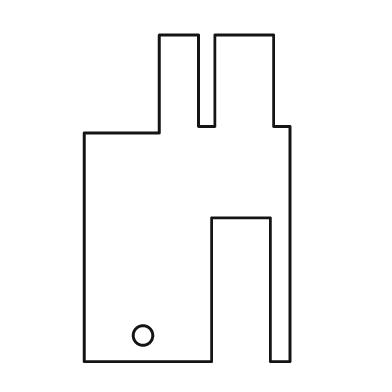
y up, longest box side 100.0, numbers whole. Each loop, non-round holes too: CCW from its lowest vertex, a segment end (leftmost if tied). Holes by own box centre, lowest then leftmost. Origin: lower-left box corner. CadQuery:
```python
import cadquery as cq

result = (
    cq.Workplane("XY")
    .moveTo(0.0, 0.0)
    .lineTo(39.0, 0.0)
    .lineTo(39.0, 44.0)
    .lineTo(57.0, 44.0)
    .lineTo(57.0, 0.0)
    .lineTo(63.0, 0.0)
    .lineTo(63.0, 72.0)
    .lineTo(58.0, 72.0)
    .lineTo(58.0, 100.0)
    .lineTo(40.0, 100.0)
    .lineTo(40.0, 72.0)
    .lineTo(35.0, 72.0)
    .lineTo(35.0, 100.0)
    .lineTo(23.0, 100.0)
    .lineTo(23.0, 70.0)
    .lineTo(0.0, 70.0)
    .close()
    .moveTo(18.0, 8.0)
    .circle(3.0)
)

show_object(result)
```